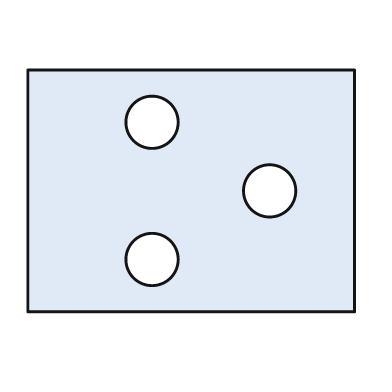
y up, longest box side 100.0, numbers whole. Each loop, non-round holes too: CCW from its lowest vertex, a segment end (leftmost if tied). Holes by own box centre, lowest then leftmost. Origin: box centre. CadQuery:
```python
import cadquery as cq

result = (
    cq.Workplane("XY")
    .moveTo(-50.0, -37.0)
    .lineTo(50.0, -37.0)
    .lineTo(50.0, 37.0)
    .lineTo(-50.0, 37.0)
    .close()
    .moveTo(-12.0, -21.0)
    .circle(8.0)
    .moveTo(24.0, 0.0)
    .circle(8.0)
    .moveTo(-12.0, 21.0)
    .circle(8.0)
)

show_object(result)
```